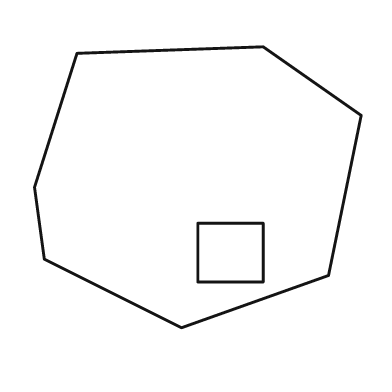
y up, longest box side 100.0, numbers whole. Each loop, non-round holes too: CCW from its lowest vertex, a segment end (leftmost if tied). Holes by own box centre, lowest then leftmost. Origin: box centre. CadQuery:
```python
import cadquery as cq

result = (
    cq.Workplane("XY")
    .moveTo(-5.0, -43.0)
    .lineTo(40.0, -27.0)
    .lineTo(50.0, 22.0)
    .lineTo(20.0, 43.0)
    .lineTo(-37.0, 41.0)
    .lineTo(-50.0, 0.0)
    .lineTo(-47.0, -22.0)
    .close()
    .moveTo(0.0, -29.0)
    .lineTo(20.0, -29.0)
    .lineTo(20.0, -11.0)
    .lineTo(0.0, -11.0)
    .close()
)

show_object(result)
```